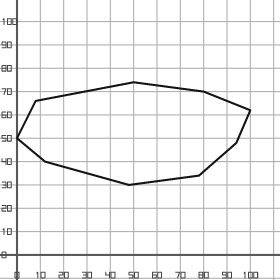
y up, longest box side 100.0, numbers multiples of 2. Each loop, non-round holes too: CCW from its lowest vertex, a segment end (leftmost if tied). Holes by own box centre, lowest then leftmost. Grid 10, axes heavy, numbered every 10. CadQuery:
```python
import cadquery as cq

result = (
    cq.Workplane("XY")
    .moveTo(48.0, 30.0)
    .lineTo(78.0, 34.0)
    .lineTo(94.0, 48.0)
    .lineTo(100.0, 62.0)
    .lineTo(80.0, 70.0)
    .lineTo(50.0, 74.0)
    .lineTo(8.0, 66.0)
    .lineTo(0.0, 50.0)
    .lineTo(12.0, 40.0)
    .close()
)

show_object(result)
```